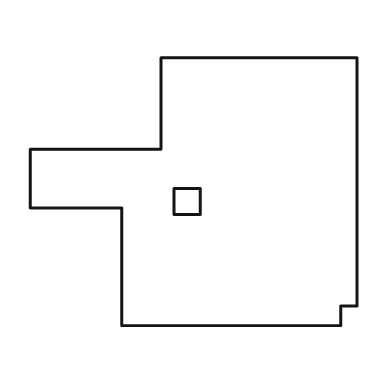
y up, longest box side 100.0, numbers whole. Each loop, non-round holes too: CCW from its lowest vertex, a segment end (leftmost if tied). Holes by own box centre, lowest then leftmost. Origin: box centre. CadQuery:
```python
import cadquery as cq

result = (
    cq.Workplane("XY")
    .moveTo(-22.0, -41.0)
    .lineTo(45.0, -41.0)
    .lineTo(45.0, -35.0)
    .lineTo(50.0, -35.0)
    .lineTo(50.0, 41.0)
    .lineTo(-10.0, 41.0)
    .lineTo(-10.0, 13.0)
    .lineTo(-50.0, 13.0)
    .lineTo(-50.0, -5.0)
    .lineTo(-22.0, -5.0)
    .close()
    .moveTo(-6.0, -7.0)
    .lineTo(2.0, -7.0)
    .lineTo(2.0, 1.0)
    .lineTo(-6.0, 1.0)
    .close()
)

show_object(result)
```